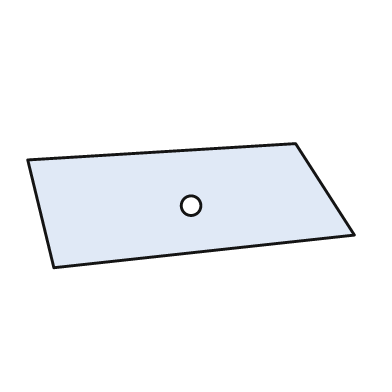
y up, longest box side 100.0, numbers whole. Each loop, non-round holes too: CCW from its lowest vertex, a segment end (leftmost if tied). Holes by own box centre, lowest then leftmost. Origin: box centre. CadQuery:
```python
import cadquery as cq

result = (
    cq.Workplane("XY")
    .moveTo(-42.0, -19.0)
    .lineTo(50.0, -9.0)
    .lineTo(32.0, 19.0)
    .lineTo(-50.0, 14.0)
    .close()
    .moveTo(0.0, 0.0)
    .circle(3.0)
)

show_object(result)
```